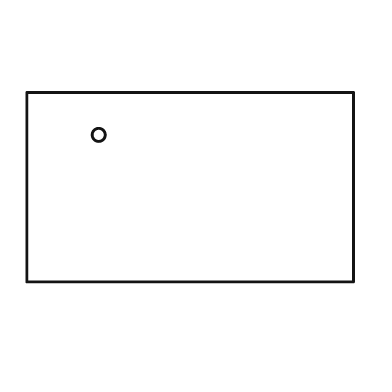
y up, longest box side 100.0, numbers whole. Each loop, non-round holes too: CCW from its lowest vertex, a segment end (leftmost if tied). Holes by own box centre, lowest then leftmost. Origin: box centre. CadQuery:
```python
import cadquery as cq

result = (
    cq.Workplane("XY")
    .moveTo(-50.0, -29.0)
    .lineTo(50.0, -29.0)
    .lineTo(50.0, 29.0)
    .lineTo(-50.0, 29.0)
    .close()
    .moveTo(-28.0, 16.0)
    .circle(2.0)
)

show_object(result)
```